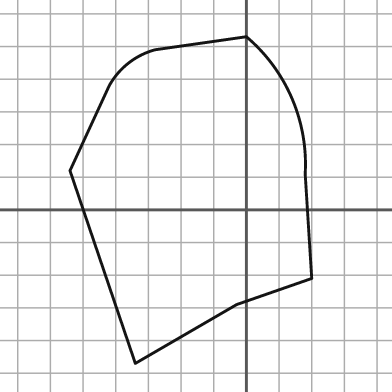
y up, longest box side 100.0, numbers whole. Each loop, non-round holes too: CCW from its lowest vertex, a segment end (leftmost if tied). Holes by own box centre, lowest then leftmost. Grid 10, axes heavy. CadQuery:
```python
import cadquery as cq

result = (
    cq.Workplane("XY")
    .moveTo(-34.0, -47.0)
    .lineTo(-3.0, -29.0)
    .lineTo(20.0, -21.0)
    .lineTo(18.0, 11.0)
    .threePointArc((14.0, 34.0), (0.0, 53.0))
    .lineTo(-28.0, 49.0)
    .threePointArc((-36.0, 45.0), (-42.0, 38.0))
    .lineTo(-54.0, 12.0)
    .close()
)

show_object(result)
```